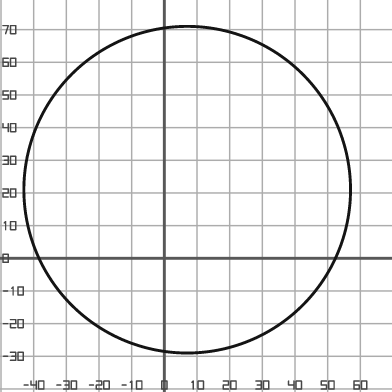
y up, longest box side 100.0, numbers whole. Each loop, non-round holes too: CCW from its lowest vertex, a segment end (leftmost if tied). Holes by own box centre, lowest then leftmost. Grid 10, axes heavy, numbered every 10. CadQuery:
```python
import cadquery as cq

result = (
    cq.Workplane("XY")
    .moveTo(7.0, 21.0)
    .circle(50.0)
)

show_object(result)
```